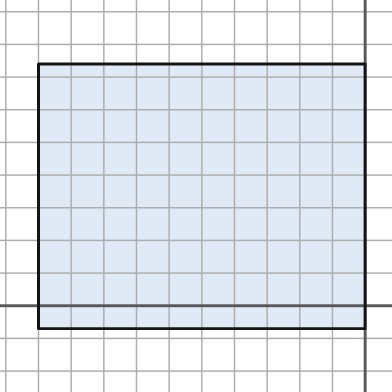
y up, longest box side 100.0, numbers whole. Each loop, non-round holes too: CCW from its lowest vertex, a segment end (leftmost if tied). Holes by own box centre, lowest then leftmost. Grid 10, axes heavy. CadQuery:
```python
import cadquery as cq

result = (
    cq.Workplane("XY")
    .moveTo(-100.0, -7.0)
    .lineTo(0.0, -7.0)
    .lineTo(0.0, 74.0)
    .lineTo(-100.0, 74.0)
    .close()
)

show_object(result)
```